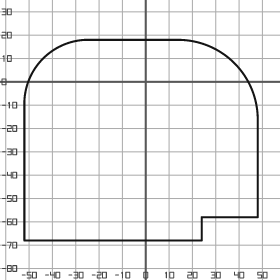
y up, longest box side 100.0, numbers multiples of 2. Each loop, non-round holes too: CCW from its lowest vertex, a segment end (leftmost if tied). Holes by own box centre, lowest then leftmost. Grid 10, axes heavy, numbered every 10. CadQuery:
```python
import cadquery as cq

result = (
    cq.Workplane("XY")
    .moveTo(-52.0, -68.0)
    .lineTo(24.0, -68.0)
    .lineTo(24.0, -58.0)
    .lineTo(48.0, -58.0)
    .lineTo(48.0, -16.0)
    .threePointArc((38.0, 8.0), (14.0, 18.0))
    .lineTo(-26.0, 18.0)
    .threePointArc((-44.0, 10.0), (-52.0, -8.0))
    .close()
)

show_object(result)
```